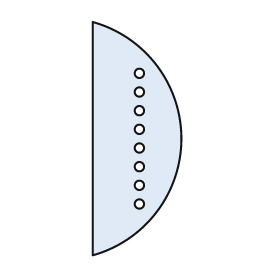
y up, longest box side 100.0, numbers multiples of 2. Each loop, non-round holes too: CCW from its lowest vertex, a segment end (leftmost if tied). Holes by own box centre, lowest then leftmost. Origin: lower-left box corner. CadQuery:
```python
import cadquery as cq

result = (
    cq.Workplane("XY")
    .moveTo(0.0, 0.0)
    .threePointArc((38.0, 50.0), (0.0, 100.0))
    .close()
    .moveTo(20.0, 22.0)
    .circle(2.0)
    .moveTo(20.0, 30.0)
    .circle(2.0)
    .moveTo(20.0, 38.0)
    .circle(2.0)
    .moveTo(20.0, 46.0)
    .circle(2.0)
    .moveTo(20.0, 54.0)
    .circle(2.0)
    .moveTo(20.0, 62.0)
    .circle(2.0)
    .moveTo(20.0, 70.0)
    .circle(2.0)
    .moveTo(20.0, 78.0)
    .circle(2.0)
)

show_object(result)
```